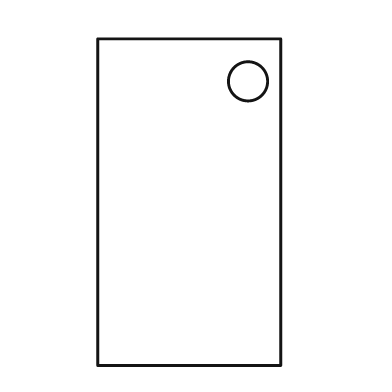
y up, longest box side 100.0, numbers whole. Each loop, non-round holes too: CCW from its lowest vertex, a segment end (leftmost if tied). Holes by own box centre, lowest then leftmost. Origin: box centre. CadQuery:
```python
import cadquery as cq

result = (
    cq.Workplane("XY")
    .moveTo(-28.0, -50.0)
    .lineTo(28.0, -50.0)
    .lineTo(28.0, 50.0)
    .lineTo(-28.0, 50.0)
    .close()
    .moveTo(18.0, 37.0)
    .circle(6.0)
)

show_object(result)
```